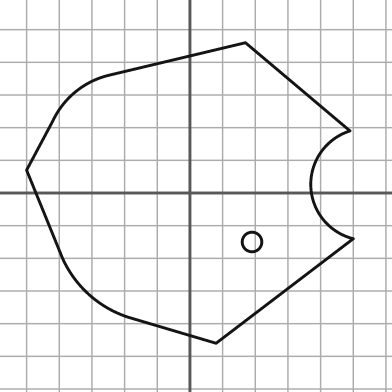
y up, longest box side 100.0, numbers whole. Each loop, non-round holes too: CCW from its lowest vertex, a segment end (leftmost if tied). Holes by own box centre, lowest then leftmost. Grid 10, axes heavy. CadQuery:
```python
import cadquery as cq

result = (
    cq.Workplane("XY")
    .moveTo(8.0, -46.0)
    .lineTo(50.0, -14.0)
    .threePointArc((37.0, 2.0), (49.0, 19.0))
    .lineTo(17.0, 46.0)
    .lineTo(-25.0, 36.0)
    .threePointArc((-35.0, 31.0), (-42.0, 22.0))
    .lineTo(-50.0, 7.0)
    .lineTo(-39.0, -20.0)
    .threePointArc((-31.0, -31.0), (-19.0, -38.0))
    .close()
    .moveTo(19.0, -15.0)
    .circle(3.0)
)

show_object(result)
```